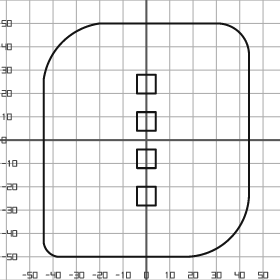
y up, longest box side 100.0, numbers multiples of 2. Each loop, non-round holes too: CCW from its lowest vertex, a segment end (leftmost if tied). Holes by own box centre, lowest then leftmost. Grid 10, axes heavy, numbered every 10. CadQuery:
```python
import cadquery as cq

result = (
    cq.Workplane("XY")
    .moveTo(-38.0, -50.0)
    .lineTo(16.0, -50.0)
    .threePointArc((36.0, -42.0), (44.0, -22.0))
    .lineTo(44.0, 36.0)
    .threePointArc((40.0, 46.0), (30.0, 50.0))
    .lineTo(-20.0, 50.0)
    .threePointArc((-36.0, 42.0), (-44.0, 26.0))
    .lineTo(-44.0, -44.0)
    .threePointArc((-42.0, -48.0), (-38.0, -50.0))
    .close()
    .moveTo(-4.0, -28.0)
    .lineTo(4.0, -28.0)
    .lineTo(4.0, -20.0)
    .lineTo(-4.0, -20.0)
    .close()
    .moveTo(-4.0, -12.0)
    .lineTo(4.0, -12.0)
    .lineTo(4.0, -4.0)
    .lineTo(-4.0, -4.0)
    .close()
    .moveTo(-4.0, 4.0)
    .lineTo(4.0, 4.0)
    .lineTo(4.0, 12.0)
    .lineTo(-4.0, 12.0)
    .close()
    .moveTo(-4.0, 20.0)
    .lineTo(4.0, 20.0)
    .lineTo(4.0, 28.0)
    .lineTo(-4.0, 28.0)
    .close()
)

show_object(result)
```